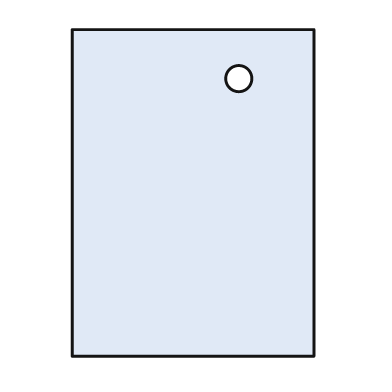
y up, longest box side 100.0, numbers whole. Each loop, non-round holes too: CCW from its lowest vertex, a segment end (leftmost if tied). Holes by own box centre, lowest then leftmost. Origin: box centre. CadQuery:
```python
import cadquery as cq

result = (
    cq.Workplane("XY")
    .moveTo(-37.0, -50.0)
    .lineTo(37.0, -50.0)
    .lineTo(37.0, 50.0)
    .lineTo(-37.0, 50.0)
    .close()
    .moveTo(14.0, 35.0)
    .circle(4.0)
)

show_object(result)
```